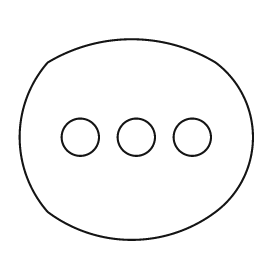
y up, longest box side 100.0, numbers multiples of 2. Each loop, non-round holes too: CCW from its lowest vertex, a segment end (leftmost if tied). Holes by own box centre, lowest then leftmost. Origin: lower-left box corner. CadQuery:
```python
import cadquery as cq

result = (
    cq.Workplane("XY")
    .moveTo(12.0, 12.0)
    .threePointArc((48.0, 0.0), (84.0, 12.0))
    .threePointArc((100.0, 44.0), (84.0, 76.0))
    .threePointArc((48.0, 86.0), (12.0, 76.0))
    .threePointArc((0.0, 44.0), (12.0, 12.0))
    .close()
    .moveTo(26.0, 44.0)
    .circle(8.0)
    .moveTo(50.0, 44.0)
    .circle(8.0)
    .moveTo(74.0, 44.0)
    .circle(8.0)
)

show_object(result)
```